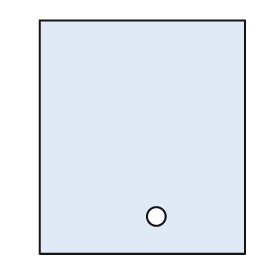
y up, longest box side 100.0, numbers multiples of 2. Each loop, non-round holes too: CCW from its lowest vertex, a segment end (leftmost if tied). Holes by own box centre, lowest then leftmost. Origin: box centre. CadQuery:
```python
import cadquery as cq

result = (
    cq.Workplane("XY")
    .moveTo(-44.0, -50.0)
    .lineTo(44.0, -50.0)
    .lineTo(44.0, 50.0)
    .lineTo(-44.0, 50.0)
    .close()
    .moveTo(6.0, -34.0)
    .circle(4.0)
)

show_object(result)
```